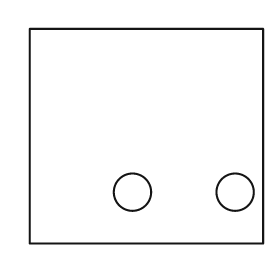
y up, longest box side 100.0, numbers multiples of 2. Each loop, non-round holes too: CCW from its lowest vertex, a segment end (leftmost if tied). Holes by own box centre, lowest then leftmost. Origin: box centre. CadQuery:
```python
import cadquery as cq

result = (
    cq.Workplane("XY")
    .moveTo(-50.0, -46.0)
    .lineTo(50.0, -46.0)
    .lineTo(50.0, 46.0)
    .lineTo(-50.0, 46.0)
    .close()
    .moveTo(-6.0, -24.0)
    .circle(8.0)
    .moveTo(38.0, -24.0)
    .circle(8.0)
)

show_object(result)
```